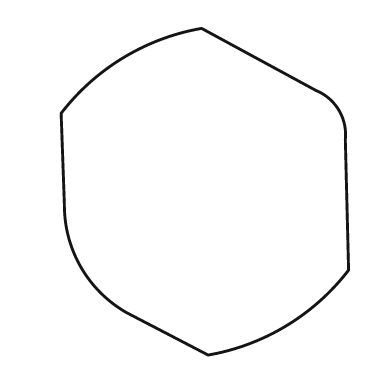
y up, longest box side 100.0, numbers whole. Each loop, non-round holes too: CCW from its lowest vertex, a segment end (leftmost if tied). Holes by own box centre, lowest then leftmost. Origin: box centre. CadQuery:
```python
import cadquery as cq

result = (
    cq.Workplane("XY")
    .moveTo(1.0, -50.0)
    .threePointArc((25.0, -41.0), (44.0, -24.0))
    .lineTo(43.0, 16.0)
    .threePointArc((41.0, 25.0), (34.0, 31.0))
    .lineTo(-1.0, 50.0)
    .threePointArc((-25.0, 41.0), (-44.0, 24.0))
    .lineTo(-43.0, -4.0)
    .threePointArc((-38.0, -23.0), (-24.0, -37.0))
    .close()
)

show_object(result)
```